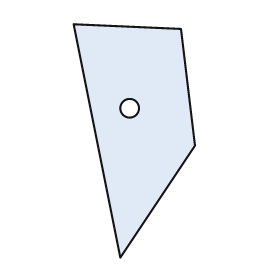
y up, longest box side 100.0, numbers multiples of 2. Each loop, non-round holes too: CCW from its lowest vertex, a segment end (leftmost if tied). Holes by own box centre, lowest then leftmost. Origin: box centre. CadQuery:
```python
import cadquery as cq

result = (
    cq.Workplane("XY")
    .moveTo(-6.0, -50.0)
    .lineTo(26.0, -2.0)
    .lineTo(20.0, 48.0)
    .lineTo(-26.0, 50.0)
    .close()
    .moveTo(-2.0, 14.0)
    .circle(4.0)
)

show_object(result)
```